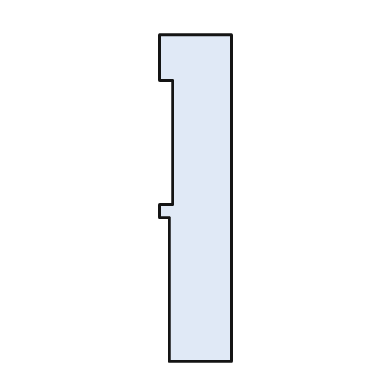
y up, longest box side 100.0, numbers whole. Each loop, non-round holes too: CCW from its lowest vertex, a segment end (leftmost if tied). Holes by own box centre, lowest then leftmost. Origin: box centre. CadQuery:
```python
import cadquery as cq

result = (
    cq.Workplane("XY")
    .moveTo(-8.0, -50.0)
    .lineTo(11.0, -50.0)
    .lineTo(11.0, 50.0)
    .lineTo(-11.0, 50.0)
    .lineTo(-11.0, 36.0)
    .lineTo(-7.0, 36.0)
    .lineTo(-7.0, -2.0)
    .lineTo(-11.0, -2.0)
    .lineTo(-11.0, -6.0)
    .lineTo(-8.0, -6.0)
    .close()
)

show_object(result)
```